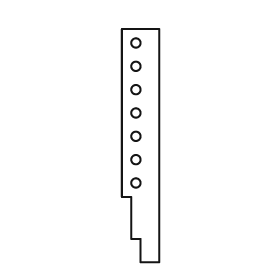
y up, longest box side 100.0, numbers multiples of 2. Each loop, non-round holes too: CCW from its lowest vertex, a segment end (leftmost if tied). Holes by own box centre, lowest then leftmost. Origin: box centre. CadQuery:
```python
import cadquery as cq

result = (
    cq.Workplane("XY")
    .moveTo(0.0, -50.0)
    .lineTo(8.0, -50.0)
    .lineTo(8.0, 50.0)
    .lineTo(-8.0, 50.0)
    .lineTo(-8.0, -22.0)
    .lineTo(-4.0, -22.0)
    .lineTo(-4.0, -40.0)
    .lineTo(0.0, -40.0)
    .close()
    .moveTo(-2.0, -16.0)
    .circle(2.0)
    .moveTo(-2.0, -6.0)
    .circle(2.0)
    .moveTo(-2.0, 4.0)
    .circle(2.0)
    .moveTo(-2.0, 14.0)
    .circle(2.0)
    .moveTo(-2.0, 24.0)
    .circle(2.0)
    .moveTo(-2.0, 34.0)
    .circle(2.0)
    .moveTo(-2.0, 44.0)
    .circle(2.0)
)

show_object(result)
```